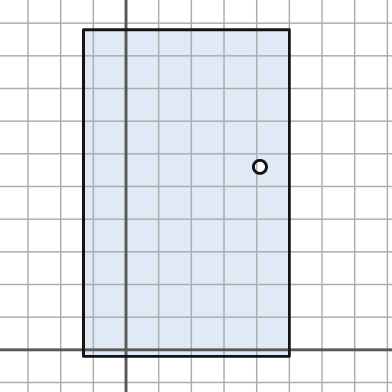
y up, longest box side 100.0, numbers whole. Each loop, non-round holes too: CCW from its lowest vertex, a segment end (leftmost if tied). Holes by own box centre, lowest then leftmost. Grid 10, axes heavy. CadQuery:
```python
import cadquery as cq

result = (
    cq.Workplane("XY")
    .moveTo(-13.0, -2.0)
    .lineTo(50.0, -2.0)
    .lineTo(50.0, 98.0)
    .lineTo(-13.0, 98.0)
    .close()
    .moveTo(41.0, 56.0)
    .circle(2.0)
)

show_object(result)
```